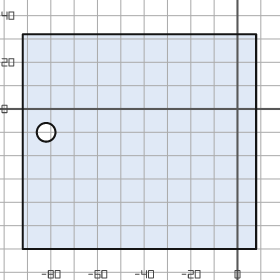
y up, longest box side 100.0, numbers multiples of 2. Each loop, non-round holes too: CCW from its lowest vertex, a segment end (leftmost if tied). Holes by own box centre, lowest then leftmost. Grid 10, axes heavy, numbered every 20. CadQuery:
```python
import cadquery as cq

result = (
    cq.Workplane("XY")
    .moveTo(-92.0, -60.0)
    .lineTo(8.0, -60.0)
    .lineTo(8.0, 32.0)
    .lineTo(-92.0, 32.0)
    .close()
    .moveTo(-82.0, -10.0)
    .circle(4.0)
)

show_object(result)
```